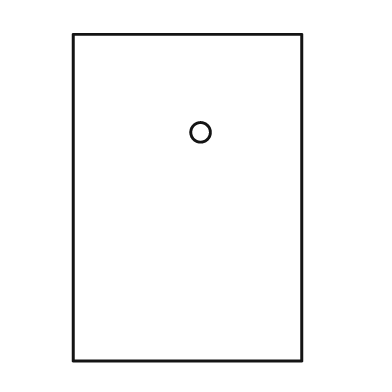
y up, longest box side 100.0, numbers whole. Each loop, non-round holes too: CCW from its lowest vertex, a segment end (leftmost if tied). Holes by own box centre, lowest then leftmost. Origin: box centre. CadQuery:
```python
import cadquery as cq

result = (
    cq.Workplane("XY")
    .moveTo(-35.0, -50.0)
    .lineTo(35.0, -50.0)
    .lineTo(35.0, 50.0)
    .lineTo(-35.0, 50.0)
    .close()
    .moveTo(4.0, 20.0)
    .circle(3.0)
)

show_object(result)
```